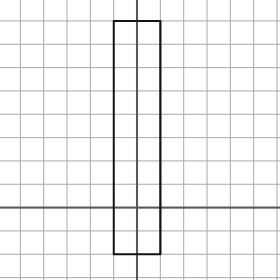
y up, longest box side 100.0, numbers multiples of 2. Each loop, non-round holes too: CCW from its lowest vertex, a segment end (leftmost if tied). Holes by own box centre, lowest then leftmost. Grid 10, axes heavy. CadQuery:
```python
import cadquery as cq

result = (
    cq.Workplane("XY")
    .moveTo(-10.0, -20.0)
    .lineTo(10.0, -20.0)
    .lineTo(10.0, 80.0)
    .lineTo(-10.0, 80.0)
    .close()
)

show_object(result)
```